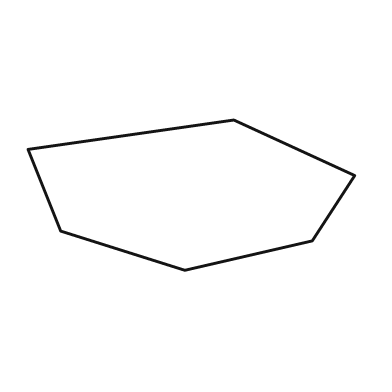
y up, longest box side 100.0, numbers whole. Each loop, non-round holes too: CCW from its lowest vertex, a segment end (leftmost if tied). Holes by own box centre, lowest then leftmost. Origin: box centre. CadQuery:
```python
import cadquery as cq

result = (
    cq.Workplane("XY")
    .moveTo(-2.0, -23.0)
    .lineTo(37.0, -14.0)
    .lineTo(50.0, 6.0)
    .lineTo(13.0, 23.0)
    .lineTo(-50.0, 14.0)
    .lineTo(-40.0, -11.0)
    .close()
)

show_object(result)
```